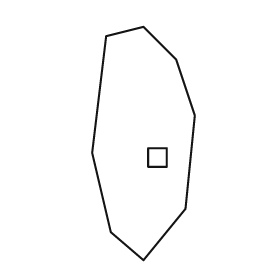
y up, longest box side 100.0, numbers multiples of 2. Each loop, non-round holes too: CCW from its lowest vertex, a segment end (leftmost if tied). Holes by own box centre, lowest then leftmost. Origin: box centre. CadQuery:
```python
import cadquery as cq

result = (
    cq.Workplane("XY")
    .moveTo(0.0, -50.0)
    .lineTo(18.0, -28.0)
    .lineTo(22.0, 12.0)
    .lineTo(14.0, 36.0)
    .lineTo(0.0, 50.0)
    .lineTo(-16.0, 46.0)
    .lineTo(-22.0, -4.0)
    .lineTo(-14.0, -38.0)
    .close()
    .moveTo(2.0, -10.0)
    .lineTo(10.0, -10.0)
    .lineTo(10.0, -2.0)
    .lineTo(2.0, -2.0)
    .close()
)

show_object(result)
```